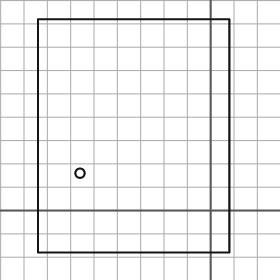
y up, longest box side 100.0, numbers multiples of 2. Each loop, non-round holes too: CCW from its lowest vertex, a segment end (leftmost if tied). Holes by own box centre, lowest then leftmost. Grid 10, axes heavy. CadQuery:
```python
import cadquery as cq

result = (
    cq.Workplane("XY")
    .moveTo(-74.0, -18.0)
    .lineTo(8.0, -18.0)
    .lineTo(8.0, 82.0)
    .lineTo(-74.0, 82.0)
    .close()
    .moveTo(-56.0, 16.0)
    .circle(2.0)
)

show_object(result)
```